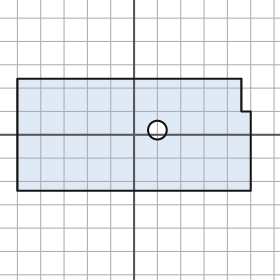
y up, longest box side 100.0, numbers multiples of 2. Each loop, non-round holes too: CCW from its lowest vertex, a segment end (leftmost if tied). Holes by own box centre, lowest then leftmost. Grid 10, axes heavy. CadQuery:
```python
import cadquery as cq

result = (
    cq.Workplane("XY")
    .moveTo(-50.0, -24.0)
    .lineTo(50.0, -24.0)
    .lineTo(50.0, 10.0)
    .lineTo(46.0, 10.0)
    .lineTo(46.0, 24.0)
    .lineTo(-50.0, 24.0)
    .close()
    .moveTo(10.0, 2.0)
    .circle(4.0)
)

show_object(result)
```